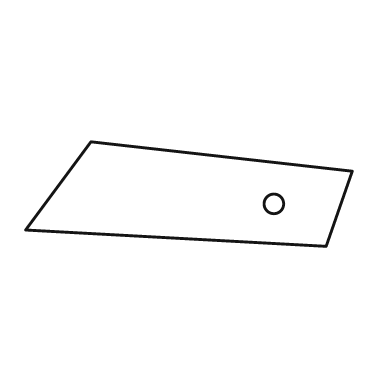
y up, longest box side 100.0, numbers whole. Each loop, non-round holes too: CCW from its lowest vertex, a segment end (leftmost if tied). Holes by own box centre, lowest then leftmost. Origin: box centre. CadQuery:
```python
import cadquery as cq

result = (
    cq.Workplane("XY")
    .moveTo(42.0, -16.0)
    .lineTo(50.0, 7.0)
    .lineTo(-30.0, 16.0)
    .lineTo(-50.0, -11.0)
    .close()
    .moveTo(26.0, -3.0)
    .circle(3.0)
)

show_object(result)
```